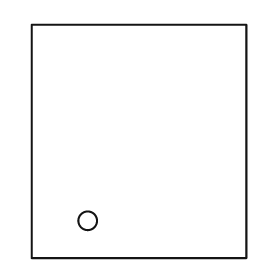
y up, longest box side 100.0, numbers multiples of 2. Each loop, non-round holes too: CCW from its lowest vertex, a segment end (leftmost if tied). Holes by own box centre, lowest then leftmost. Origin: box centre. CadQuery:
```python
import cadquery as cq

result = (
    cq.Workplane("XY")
    .moveTo(-46.0, -50.0)
    .lineTo(46.0, -50.0)
    .lineTo(46.0, 50.0)
    .lineTo(-46.0, 50.0)
    .close()
    .moveTo(-22.0, -34.0)
    .circle(4.0)
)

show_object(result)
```